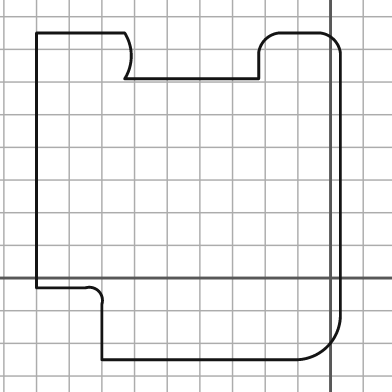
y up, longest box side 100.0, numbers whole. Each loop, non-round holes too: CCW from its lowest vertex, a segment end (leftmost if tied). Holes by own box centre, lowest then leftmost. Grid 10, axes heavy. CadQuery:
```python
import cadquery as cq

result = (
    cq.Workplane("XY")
    .moveTo(-70.0, -25.0)
    .lineTo(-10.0, -25.0)
    .threePointArc((-1.0, -21.0), (3.0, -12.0))
    .lineTo(3.0, 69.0)
    .threePointArc((1.0, 73.0), (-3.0, 75.0))
    .lineTo(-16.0, 75.0)
    .threePointArc((-20.0, 73.0), (-22.0, 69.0))
    .lineTo(-22.0, 61.0)
    .lineTo(-63.0, 61.0)
    .threePointArc((-61.0, 68.0), (-63.0, 75.0))
    .lineTo(-90.0, 75.0)
    .lineTo(-90.0, -3.0)
    .lineTo(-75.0, -3.0)
    .threePointArc((-71.0, -4.0), (-70.0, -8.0))
    .close()
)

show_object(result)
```